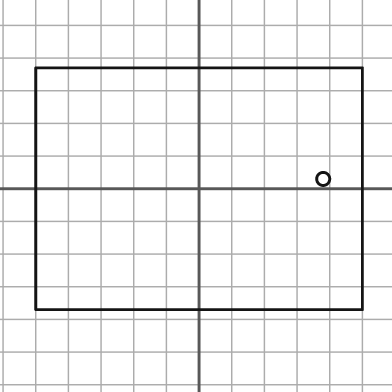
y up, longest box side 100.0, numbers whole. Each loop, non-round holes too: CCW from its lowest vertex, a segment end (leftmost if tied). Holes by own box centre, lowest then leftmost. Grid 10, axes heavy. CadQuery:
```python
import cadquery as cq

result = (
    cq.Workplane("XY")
    .moveTo(-50.0, -37.0)
    .lineTo(50.0, -37.0)
    .lineTo(50.0, 37.0)
    .lineTo(-50.0, 37.0)
    .close()
    .moveTo(38.0, 3.0)
    .circle(2.0)
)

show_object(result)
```